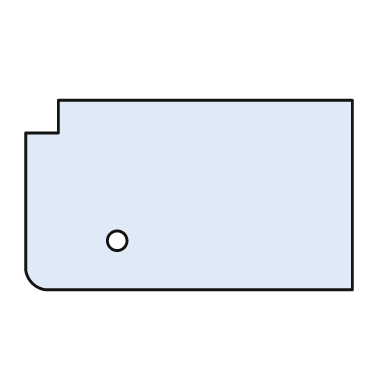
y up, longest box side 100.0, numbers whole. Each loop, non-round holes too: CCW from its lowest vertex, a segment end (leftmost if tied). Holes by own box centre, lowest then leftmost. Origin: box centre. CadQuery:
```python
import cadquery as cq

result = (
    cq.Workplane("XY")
    .moveTo(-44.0, -29.0)
    .lineTo(50.0, -29.0)
    .lineTo(50.0, 29.0)
    .lineTo(-40.0, 29.0)
    .lineTo(-40.0, 19.0)
    .lineTo(-50.0, 19.0)
    .lineTo(-50.0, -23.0)
    .threePointArc((-48.0, -27.0), (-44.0, -29.0))
    .close()
    .moveTo(-22.0, -14.0)
    .circle(3.0)
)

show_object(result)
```